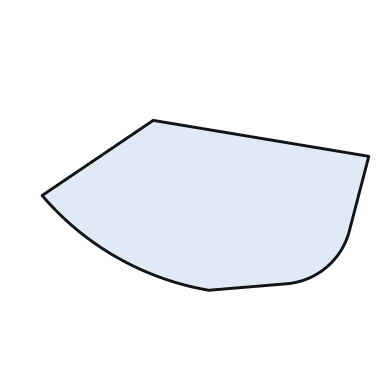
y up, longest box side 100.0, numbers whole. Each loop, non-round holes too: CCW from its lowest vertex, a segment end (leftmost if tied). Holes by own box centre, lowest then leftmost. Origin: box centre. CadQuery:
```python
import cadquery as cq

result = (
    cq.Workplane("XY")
    .moveTo(1.0, -26.0)
    .lineTo(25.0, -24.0)
    .threePointArc((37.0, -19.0), (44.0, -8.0))
    .lineTo(50.0, 15.0)
    .lineTo(-16.0, 26.0)
    .lineTo(-50.0, 3.0)
    .threePointArc((-27.0, -16.0), (1.0, -26.0))
    .close()
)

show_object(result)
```